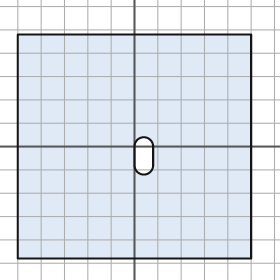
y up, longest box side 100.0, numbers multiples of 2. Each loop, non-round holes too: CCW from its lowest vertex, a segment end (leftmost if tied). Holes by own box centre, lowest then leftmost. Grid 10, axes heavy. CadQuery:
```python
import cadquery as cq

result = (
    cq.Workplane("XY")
    .moveTo(-50.0, -48.0)
    .lineTo(50.0, -48.0)
    .lineTo(50.0, 48.0)
    .lineTo(-50.0, 48.0)
    .close()
    .moveTo(0.0, -8.0)
    .threePointArc((4.0, -12.0), (8.0, -8.0))
    .lineTo(8.0, 0.0)
    .threePointArc((4.0, 4.0), (0.0, 0.0))
    .close()
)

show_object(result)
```